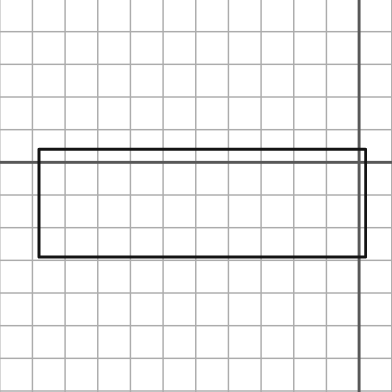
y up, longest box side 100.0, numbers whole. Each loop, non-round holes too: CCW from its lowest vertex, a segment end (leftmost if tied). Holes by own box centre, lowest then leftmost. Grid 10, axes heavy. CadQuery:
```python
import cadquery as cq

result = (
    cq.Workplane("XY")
    .moveTo(-98.0, -29.0)
    .lineTo(2.0, -29.0)
    .lineTo(2.0, 4.0)
    .lineTo(-98.0, 4.0)
    .close()
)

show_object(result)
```